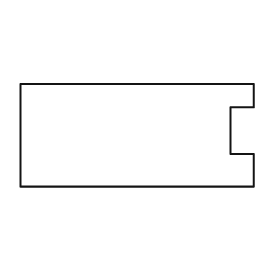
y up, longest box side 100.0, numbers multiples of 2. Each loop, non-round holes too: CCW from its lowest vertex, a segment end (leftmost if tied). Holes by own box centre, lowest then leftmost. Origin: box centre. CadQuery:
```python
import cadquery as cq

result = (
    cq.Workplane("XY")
    .moveTo(-50.0, -22.0)
    .lineTo(50.0, -22.0)
    .lineTo(50.0, -8.0)
    .lineTo(40.0, -8.0)
    .lineTo(40.0, 12.0)
    .lineTo(50.0, 12.0)
    .lineTo(50.0, 22.0)
    .lineTo(-50.0, 22.0)
    .close()
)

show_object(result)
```